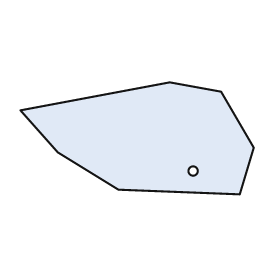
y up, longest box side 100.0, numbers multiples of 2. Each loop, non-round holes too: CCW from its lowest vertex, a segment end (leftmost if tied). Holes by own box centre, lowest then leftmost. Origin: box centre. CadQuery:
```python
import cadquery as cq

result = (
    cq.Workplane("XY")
    .moveTo(44.0, -24.0)
    .lineTo(50.0, -4.0)
    .lineTo(36.0, 20.0)
    .lineTo(14.0, 24.0)
    .lineTo(-50.0, 12.0)
    .lineTo(-34.0, -6.0)
    .lineTo(-8.0, -22.0)
    .close()
    .moveTo(24.0, -14.0)
    .circle(2.0)
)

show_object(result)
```